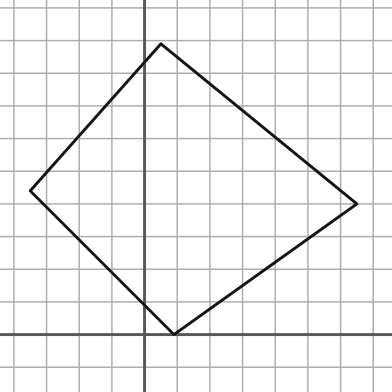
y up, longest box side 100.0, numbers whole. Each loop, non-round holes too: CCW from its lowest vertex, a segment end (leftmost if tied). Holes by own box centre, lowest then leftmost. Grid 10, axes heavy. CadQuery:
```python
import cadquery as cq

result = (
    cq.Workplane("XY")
    .moveTo(9.0, 0.0)
    .lineTo(65.0, 40.0)
    .lineTo(5.0, 89.0)
    .lineTo(-35.0, 44.0)
    .close()
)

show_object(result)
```